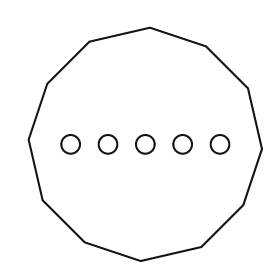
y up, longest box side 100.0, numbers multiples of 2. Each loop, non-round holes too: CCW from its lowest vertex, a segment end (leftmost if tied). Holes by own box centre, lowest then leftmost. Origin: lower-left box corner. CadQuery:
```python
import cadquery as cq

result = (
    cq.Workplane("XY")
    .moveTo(48.0, 0.0)
    .lineTo(74.0, 6.0)
    .lineTo(92.0, 24.0)
    .lineTo(100.0, 48.0)
    .lineTo(94.0, 74.0)
    .lineTo(76.0, 92.0)
    .lineTo(52.0, 100.0)
    .lineTo(26.0, 94.0)
    .lineTo(8.0, 76.0)
    .lineTo(0.0, 52.0)
    .lineTo(6.0, 26.0)
    .lineTo(24.0, 8.0)
    .close()
    .moveTo(18.0, 50.0)
    .circle(4.0)
    .moveTo(34.0, 50.0)
    .circle(4.0)
    .moveTo(50.0, 50.0)
    .circle(4.0)
    .moveTo(66.0, 50.0)
    .circle(4.0)
    .moveTo(82.0, 50.0)
    .circle(4.0)
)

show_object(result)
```